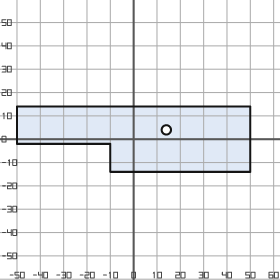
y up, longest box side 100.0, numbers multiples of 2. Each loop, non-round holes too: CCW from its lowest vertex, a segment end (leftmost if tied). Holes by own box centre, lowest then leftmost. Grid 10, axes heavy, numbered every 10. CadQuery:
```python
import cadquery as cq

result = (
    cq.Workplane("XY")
    .moveTo(-10.0, -14.0)
    .lineTo(50.0, -14.0)
    .lineTo(50.0, 14.0)
    .lineTo(-50.0, 14.0)
    .lineTo(-50.0, -2.0)
    .lineTo(-10.0, -2.0)
    .close()
    .moveTo(14.0, 4.0)
    .circle(2.0)
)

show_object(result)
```